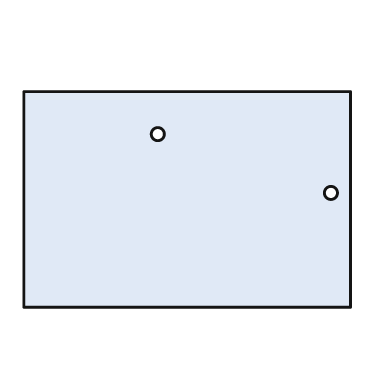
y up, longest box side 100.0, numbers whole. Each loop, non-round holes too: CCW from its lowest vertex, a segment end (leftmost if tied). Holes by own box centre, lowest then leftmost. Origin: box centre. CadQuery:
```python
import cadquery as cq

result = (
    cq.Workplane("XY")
    .moveTo(-50.0, -33.0)
    .lineTo(50.0, -33.0)
    .lineTo(50.0, 33.0)
    .lineTo(-50.0, 33.0)
    .close()
    .moveTo(44.0, 2.0)
    .circle(2.0)
    .moveTo(-9.0, 20.0)
    .circle(2.0)
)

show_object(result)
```